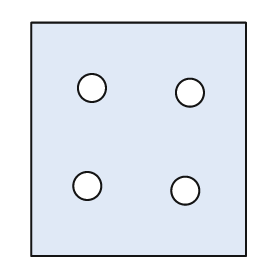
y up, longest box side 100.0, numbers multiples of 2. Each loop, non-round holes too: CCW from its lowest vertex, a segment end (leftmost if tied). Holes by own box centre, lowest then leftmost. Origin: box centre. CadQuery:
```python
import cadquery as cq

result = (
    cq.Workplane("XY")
    .moveTo(-46.0, -50.0)
    .lineTo(46.0, -50.0)
    .lineTo(46.0, 50.0)
    .lineTo(-46.0, 50.0)
    .close()
    .moveTo(20.0, -22.0)
    .circle(6.0)
    .moveTo(-22.0, -20.0)
    .circle(6.0)
    .moveTo(22.0, 20.0)
    .circle(6.0)
    .moveTo(-20.0, 22.0)
    .circle(6.0)
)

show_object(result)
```